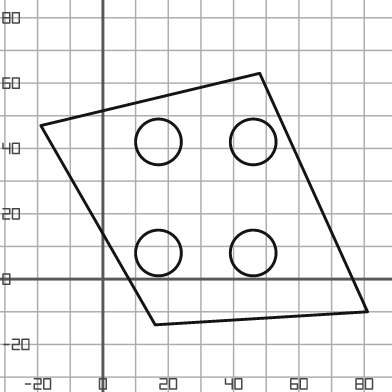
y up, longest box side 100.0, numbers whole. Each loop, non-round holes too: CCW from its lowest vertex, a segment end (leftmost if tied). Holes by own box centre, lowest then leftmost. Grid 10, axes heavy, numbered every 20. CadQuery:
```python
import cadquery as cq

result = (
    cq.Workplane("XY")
    .moveTo(16.0, -14.0)
    .lineTo(81.0, -10.0)
    .lineTo(48.0, 63.0)
    .lineTo(-19.0, 47.0)
    .close()
    .moveTo(17.0, 8.0)
    .circle(7.0)
    .moveTo(46.0, 8.0)
    .circle(7.0)
    .moveTo(17.0, 42.0)
    .circle(7.0)
    .moveTo(46.0, 42.0)
    .circle(7.0)
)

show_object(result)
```